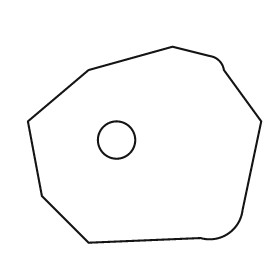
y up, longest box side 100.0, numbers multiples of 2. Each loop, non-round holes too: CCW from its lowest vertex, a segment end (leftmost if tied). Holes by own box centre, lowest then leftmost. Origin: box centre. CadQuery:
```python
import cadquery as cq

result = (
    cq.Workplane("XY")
    .moveTo(-24.0, -42.0)
    .lineTo(24.0, -40.0)
    .threePointArc((36.0, -38.0), (42.0, -28.0))
    .lineTo(50.0, 10.0)
    .lineTo(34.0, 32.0)
    .threePointArc((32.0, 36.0), (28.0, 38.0))
    .lineTo(12.0, 42.0)
    .lineTo(-24.0, 32.0)
    .lineTo(-50.0, 10.0)
    .lineTo(-44.0, -22.0)
    .close()
    .moveTo(-12.0, 2.0)
    .circle(8.0)
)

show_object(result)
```